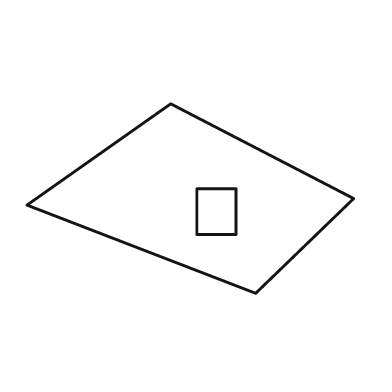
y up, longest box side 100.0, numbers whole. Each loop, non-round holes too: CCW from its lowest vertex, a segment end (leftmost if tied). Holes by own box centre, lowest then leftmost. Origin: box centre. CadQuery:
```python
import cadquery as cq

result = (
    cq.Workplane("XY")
    .moveTo(20.0, -29.0)
    .lineTo(50.0, 0.0)
    .lineTo(-6.0, 29.0)
    .lineTo(-50.0, -2.0)
    .close()
    .moveTo(2.0, -11.0)
    .lineTo(14.0, -11.0)
    .lineTo(14.0, 3.0)
    .lineTo(2.0, 3.0)
    .close()
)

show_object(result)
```